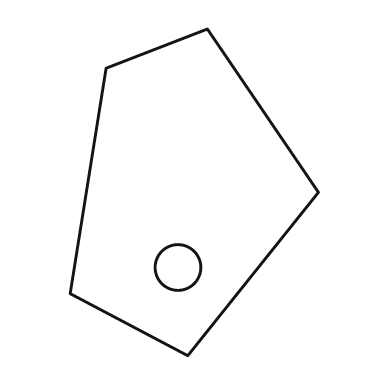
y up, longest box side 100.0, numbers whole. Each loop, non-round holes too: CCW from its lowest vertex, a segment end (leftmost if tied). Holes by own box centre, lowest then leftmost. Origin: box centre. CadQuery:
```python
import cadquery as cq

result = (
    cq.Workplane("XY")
    .moveTo(-2.0, -50.0)
    .lineTo(38.0, 0.0)
    .lineTo(4.0, 50.0)
    .lineTo(-27.0, 38.0)
    .lineTo(-38.0, -31.0)
    .close()
    .moveTo(-5.0, -23.0)
    .circle(7.0)
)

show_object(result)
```